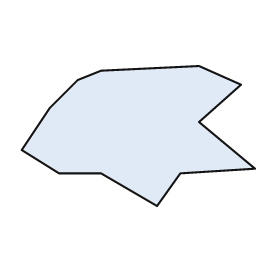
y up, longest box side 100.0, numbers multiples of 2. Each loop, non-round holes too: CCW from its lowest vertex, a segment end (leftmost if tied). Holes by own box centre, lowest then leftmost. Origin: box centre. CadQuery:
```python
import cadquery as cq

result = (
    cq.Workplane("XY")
    .moveTo(8.0, -30.0)
    .lineTo(18.0, -16.0)
    .lineTo(50.0, -14.0)
    .lineTo(26.0, 6.0)
    .lineTo(44.0, 22.0)
    .lineTo(26.0, 30.0)
    .lineTo(-16.0, 28.0)
    .lineTo(-26.0, 24.0)
    .lineTo(-38.0, 12.0)
    .lineTo(-50.0, -6.0)
    .lineTo(-34.0, -16.0)
    .lineTo(-16.0, -16.0)
    .close()
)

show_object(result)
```